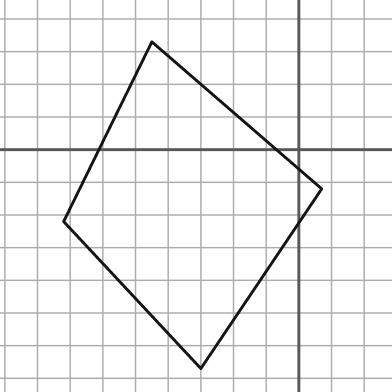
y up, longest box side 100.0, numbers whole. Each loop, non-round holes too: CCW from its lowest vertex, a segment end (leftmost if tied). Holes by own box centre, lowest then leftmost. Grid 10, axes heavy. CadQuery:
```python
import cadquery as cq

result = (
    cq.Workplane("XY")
    .moveTo(-30.0, -67.0)
    .lineTo(7.0, -12.0)
    .lineTo(-45.0, 33.0)
    .lineTo(-72.0, -22.0)
    .close()
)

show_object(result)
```